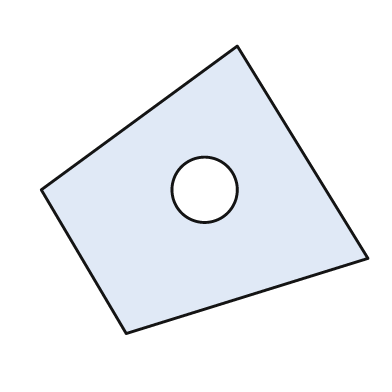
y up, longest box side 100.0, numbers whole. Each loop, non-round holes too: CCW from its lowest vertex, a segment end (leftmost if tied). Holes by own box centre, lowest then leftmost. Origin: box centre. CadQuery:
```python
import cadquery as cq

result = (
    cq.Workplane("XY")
    .moveTo(-24.0, -44.0)
    .lineTo(50.0, -21.0)
    .lineTo(10.0, 44.0)
    .lineTo(-50.0, 0.0)
    .close()
    .moveTo(0.0, 0.0)
    .circle(10.0)
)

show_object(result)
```